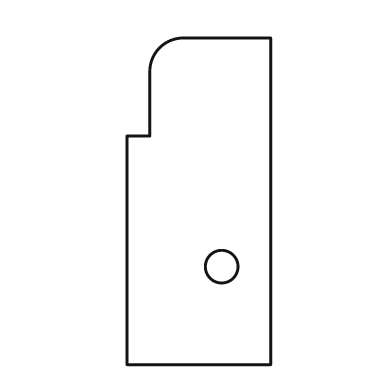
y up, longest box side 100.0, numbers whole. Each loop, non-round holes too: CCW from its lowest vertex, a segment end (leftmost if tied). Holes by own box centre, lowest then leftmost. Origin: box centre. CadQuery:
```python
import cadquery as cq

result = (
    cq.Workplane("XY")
    .moveTo(-22.0, -50.0)
    .lineTo(22.0, -50.0)
    .lineTo(22.0, 50.0)
    .lineTo(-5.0, 50.0)
    .threePointArc((-12.0, 47.0), (-15.0, 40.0))
    .lineTo(-15.0, 20.0)
    .lineTo(-22.0, 20.0)
    .close()
    .moveTo(7.0, -20.0)
    .circle(5.0)
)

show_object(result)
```